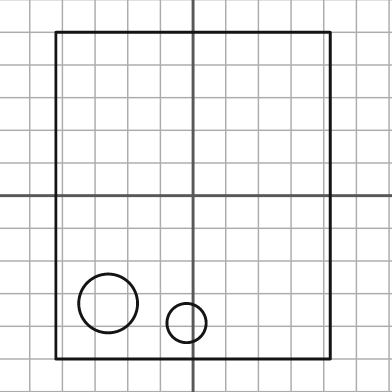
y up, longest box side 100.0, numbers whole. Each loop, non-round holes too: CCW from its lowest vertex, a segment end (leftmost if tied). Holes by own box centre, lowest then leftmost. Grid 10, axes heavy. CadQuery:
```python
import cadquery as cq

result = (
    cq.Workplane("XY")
    .moveTo(-42.0, -50.0)
    .lineTo(42.0, -50.0)
    .lineTo(42.0, 50.0)
    .lineTo(-42.0, 50.0)
    .close()
    .moveTo(-2.0, -39.0)
    .circle(6.0)
    .moveTo(-26.0, -33.0)
    .circle(9.0)
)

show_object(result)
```